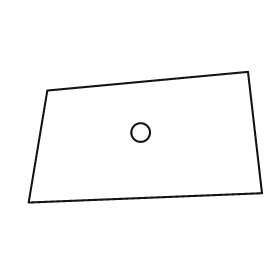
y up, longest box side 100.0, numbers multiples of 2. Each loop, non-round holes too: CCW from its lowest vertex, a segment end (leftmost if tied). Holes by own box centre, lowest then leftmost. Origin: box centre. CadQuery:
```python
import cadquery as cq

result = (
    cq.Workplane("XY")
    .moveTo(-50.0, -28.0)
    .lineTo(50.0, -24.0)
    .lineTo(44.0, 28.0)
    .lineTo(-42.0, 20.0)
    .close()
    .moveTo(-2.0, 2.0)
    .circle(4.0)
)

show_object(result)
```